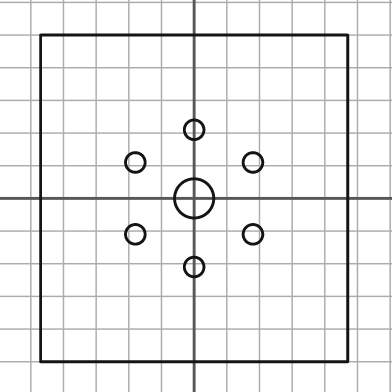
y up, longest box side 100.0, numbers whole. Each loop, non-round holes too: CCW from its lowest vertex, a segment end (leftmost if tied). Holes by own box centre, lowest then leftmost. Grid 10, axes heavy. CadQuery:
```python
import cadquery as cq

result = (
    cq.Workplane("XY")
    .moveTo(-47.0, -50.0)
    .lineTo(47.0, -50.0)
    .lineTo(47.0, 50.0)
    .lineTo(-47.0, 50.0)
    .close()
    .moveTo(0.0, -21.0)
    .circle(3.0)
    .moveTo(-18.0, -11.0)
    .circle(3.0)
    .moveTo(18.0, -11.0)
    .circle(3.0)
    .moveTo(0.0, 0.0)
    .circle(6.0)
    .moveTo(-18.0, 11.0)
    .circle(3.0)
    .moveTo(18.0, 11.0)
    .circle(3.0)
    .moveTo(0.0, 21.0)
    .circle(3.0)
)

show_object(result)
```